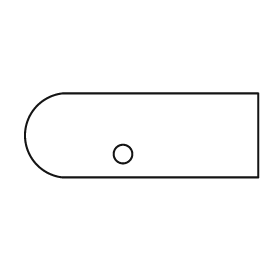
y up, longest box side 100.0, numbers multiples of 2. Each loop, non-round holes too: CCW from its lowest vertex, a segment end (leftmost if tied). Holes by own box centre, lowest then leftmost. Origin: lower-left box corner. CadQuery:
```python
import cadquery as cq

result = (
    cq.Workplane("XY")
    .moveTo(16.0, 0.0)
    .lineTo(100.0, 0.0)
    .lineTo(100.0, 36.0)
    .lineTo(16.0, 36.0)
    .threePointArc((0.0, 18.0), (16.0, 0.0))
    .close()
    .moveTo(42.0, 10.0)
    .circle(4.0)
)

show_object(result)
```